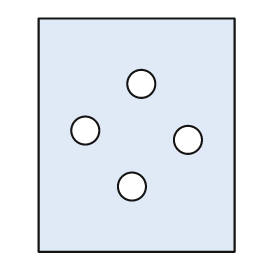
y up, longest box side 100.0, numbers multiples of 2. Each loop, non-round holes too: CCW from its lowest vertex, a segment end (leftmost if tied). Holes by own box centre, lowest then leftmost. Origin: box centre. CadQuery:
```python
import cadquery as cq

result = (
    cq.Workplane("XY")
    .moveTo(-42.0, -50.0)
    .lineTo(42.0, -50.0)
    .lineTo(42.0, 50.0)
    .lineTo(-42.0, 50.0)
    .close()
    .moveTo(-2.0, -22.0)
    .circle(6.0)
    .moveTo(22.0, -2.0)
    .circle(6.0)
    .moveTo(-22.0, 2.0)
    .circle(6.0)
    .moveTo(2.0, 22.0)
    .circle(6.0)
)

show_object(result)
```